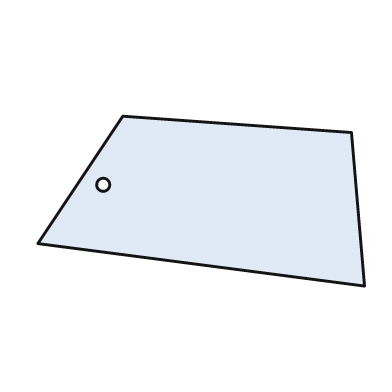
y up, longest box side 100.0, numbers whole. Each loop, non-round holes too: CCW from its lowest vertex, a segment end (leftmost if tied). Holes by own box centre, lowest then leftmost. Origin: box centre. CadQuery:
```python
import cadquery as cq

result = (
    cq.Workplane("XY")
    .moveTo(50.0, -26.0)
    .lineTo(46.0, 21.0)
    .lineTo(-24.0, 26.0)
    .lineTo(-50.0, -13.0)
    .close()
    .moveTo(-30.0, 5.0)
    .circle(2.0)
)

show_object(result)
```